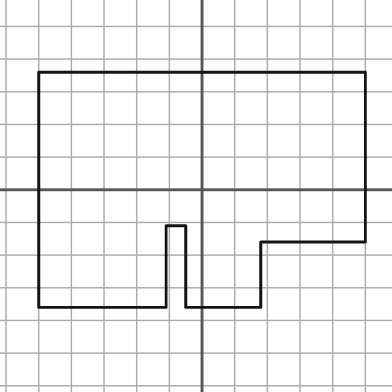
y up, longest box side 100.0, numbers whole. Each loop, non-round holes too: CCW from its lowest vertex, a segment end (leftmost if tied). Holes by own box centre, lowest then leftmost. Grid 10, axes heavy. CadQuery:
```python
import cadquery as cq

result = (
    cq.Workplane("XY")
    .moveTo(-50.0, -36.0)
    .lineTo(-11.0, -36.0)
    .lineTo(-11.0, -11.0)
    .lineTo(-5.0, -11.0)
    .lineTo(-5.0, -36.0)
    .lineTo(18.0, -36.0)
    .lineTo(18.0, -16.0)
    .lineTo(50.0, -16.0)
    .lineTo(50.0, 36.0)
    .lineTo(-50.0, 36.0)
    .close()
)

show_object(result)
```